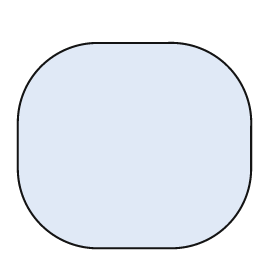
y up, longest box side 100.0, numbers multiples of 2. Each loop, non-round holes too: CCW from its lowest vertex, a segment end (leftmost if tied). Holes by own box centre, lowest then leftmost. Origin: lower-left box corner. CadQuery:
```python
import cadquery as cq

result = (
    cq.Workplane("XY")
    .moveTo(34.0, 0.0)
    .lineTo(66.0, 0.0)
    .threePointArc((90.0, 10.0), (100.0, 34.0))
    .lineTo(100.0, 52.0)
    .threePointArc((90.0, 78.0), (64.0, 88.0))
    .lineTo(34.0, 88.0)
    .threePointArc((10.0, 78.0), (0.0, 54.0))
    .lineTo(0.0, 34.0)
    .threePointArc((10.0, 10.0), (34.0, 0.0))
    .close()
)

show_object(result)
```